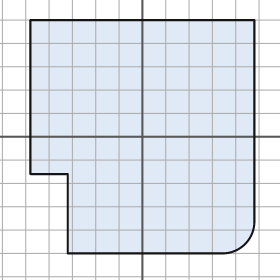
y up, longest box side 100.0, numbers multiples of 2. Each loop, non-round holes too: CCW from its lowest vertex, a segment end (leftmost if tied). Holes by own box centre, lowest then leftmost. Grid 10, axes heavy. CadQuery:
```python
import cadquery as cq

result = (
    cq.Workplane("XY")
    .moveTo(-32.0, -50.0)
    .lineTo(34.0, -50.0)
    .threePointArc((44.0, -46.0), (48.0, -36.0))
    .lineTo(48.0, 50.0)
    .lineTo(-48.0, 50.0)
    .lineTo(-48.0, -16.0)
    .lineTo(-32.0, -16.0)
    .close()
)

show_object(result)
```